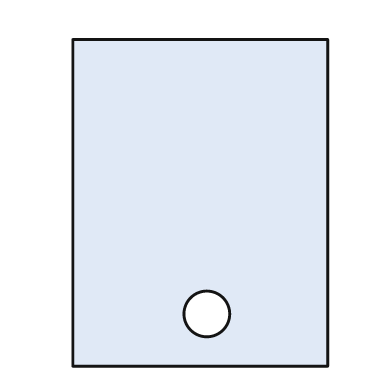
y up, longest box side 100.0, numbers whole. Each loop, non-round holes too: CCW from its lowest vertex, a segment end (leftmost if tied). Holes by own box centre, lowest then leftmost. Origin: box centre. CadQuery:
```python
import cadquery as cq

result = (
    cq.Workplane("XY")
    .moveTo(-39.0, -50.0)
    .lineTo(39.0, -50.0)
    .lineTo(39.0, 50.0)
    .lineTo(-39.0, 50.0)
    .close()
    .moveTo(2.0, -34.0)
    .circle(7.0)
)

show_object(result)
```